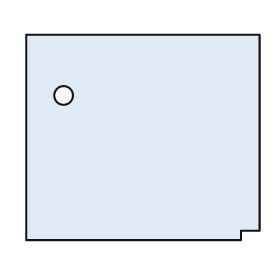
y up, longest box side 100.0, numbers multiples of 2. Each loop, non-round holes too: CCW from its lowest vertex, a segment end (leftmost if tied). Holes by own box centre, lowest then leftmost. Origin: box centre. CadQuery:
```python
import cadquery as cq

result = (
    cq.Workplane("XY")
    .moveTo(-50.0, -44.0)
    .lineTo(42.0, -44.0)
    .lineTo(42.0, -40.0)
    .lineTo(50.0, -40.0)
    .lineTo(50.0, 44.0)
    .lineTo(-50.0, 44.0)
    .close()
    .moveTo(-34.0, 18.0)
    .circle(4.0)
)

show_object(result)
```